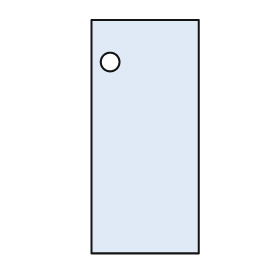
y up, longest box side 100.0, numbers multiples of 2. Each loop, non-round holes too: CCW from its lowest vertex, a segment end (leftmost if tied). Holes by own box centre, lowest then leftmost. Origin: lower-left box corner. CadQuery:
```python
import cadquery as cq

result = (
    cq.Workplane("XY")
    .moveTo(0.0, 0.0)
    .lineTo(46.0, 0.0)
    .lineTo(46.0, 100.0)
    .lineTo(0.0, 100.0)
    .close()
    .moveTo(8.0, 82.0)
    .circle(4.0)
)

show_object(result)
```